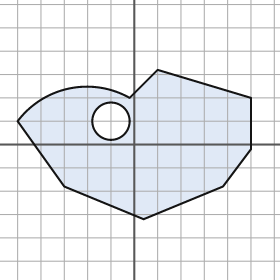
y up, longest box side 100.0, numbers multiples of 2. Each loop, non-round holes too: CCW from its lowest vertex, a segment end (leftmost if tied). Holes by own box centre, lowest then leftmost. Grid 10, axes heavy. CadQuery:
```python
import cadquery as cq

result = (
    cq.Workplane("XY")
    .moveTo(4.0, -32.0)
    .lineTo(38.0, -18.0)
    .lineTo(50.0, -2.0)
    .lineTo(50.0, 20.0)
    .lineTo(10.0, 32.0)
    .lineTo(-2.0, 20.0)
    .threePointArc((-28.0, 24.0), (-50.0, 10.0))
    .lineTo(-30.0, -18.0)
    .close()
    .moveTo(-10.0, 10.0)
    .circle(8.0)
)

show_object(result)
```